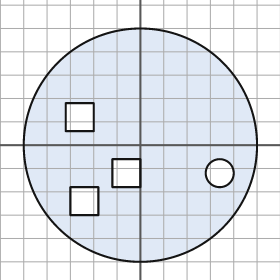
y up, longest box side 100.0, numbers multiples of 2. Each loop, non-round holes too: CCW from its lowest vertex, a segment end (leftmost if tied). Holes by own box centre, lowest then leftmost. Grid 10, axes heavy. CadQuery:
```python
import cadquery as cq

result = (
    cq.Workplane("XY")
    .moveTo(0.0, 0.0)
    .circle(50.0)
    .moveTo(-30.0, -30.0)
    .lineTo(-18.0, -30.0)
    .lineTo(-18.0, -18.0)
    .lineTo(-30.0, -18.0)
    .close()
    .moveTo(-12.0, -18.0)
    .lineTo(0.0, -18.0)
    .lineTo(0.0, -6.0)
    .lineTo(-12.0, -6.0)
    .close()
    .moveTo(34.0, -12.0)
    .circle(6.0)
    .moveTo(-32.0, 6.0)
    .lineTo(-20.0, 6.0)
    .lineTo(-20.0, 18.0)
    .lineTo(-32.0, 18.0)
    .close()
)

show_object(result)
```